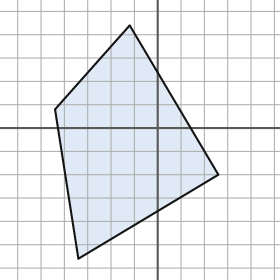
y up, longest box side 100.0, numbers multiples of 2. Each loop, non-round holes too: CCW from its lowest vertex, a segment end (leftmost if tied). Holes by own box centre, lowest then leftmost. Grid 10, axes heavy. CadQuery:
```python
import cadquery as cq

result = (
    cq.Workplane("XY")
    .moveTo(-34.0, -56.0)
    .lineTo(26.0, -20.0)
    .lineTo(-12.0, 44.0)
    .lineTo(-44.0, 8.0)
    .close()
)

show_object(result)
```